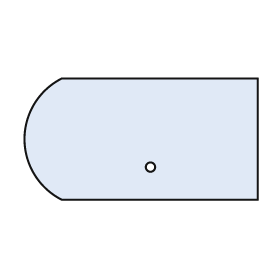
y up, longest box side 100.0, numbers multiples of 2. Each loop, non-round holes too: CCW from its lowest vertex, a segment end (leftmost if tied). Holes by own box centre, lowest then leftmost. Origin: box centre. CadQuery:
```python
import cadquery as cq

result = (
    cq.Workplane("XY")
    .moveTo(-34.0, -26.0)
    .lineTo(50.0, -26.0)
    .lineTo(50.0, 26.0)
    .lineTo(-34.0, 26.0)
    .threePointArc((-50.0, 0.0), (-34.0, -26.0))
    .close()
    .moveTo(4.0, -12.0)
    .circle(2.0)
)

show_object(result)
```